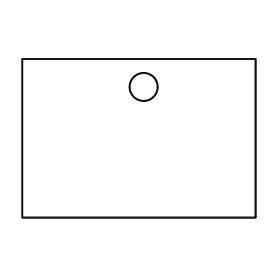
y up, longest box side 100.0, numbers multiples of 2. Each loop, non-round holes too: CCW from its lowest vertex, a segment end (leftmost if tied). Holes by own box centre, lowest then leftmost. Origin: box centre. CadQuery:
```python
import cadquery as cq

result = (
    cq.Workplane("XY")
    .moveTo(-50.0, -34.0)
    .lineTo(50.0, -34.0)
    .lineTo(50.0, 34.0)
    .lineTo(-50.0, 34.0)
    .close()
    .moveTo(2.0, 22.0)
    .circle(6.0)
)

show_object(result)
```